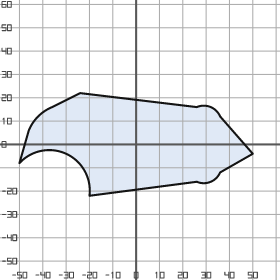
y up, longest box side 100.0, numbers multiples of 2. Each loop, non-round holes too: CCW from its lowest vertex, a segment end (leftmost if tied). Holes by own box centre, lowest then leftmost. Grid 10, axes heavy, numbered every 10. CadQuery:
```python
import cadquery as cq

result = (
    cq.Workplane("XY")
    .moveTo(-20.0, -22.0)
    .lineTo(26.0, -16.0)
    .threePointArc((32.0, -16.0), (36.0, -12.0))
    .lineTo(50.0, -4.0)
    .lineTo(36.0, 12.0)
    .threePointArc((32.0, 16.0), (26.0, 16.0))
    .lineTo(-24.0, 22.0)
    .lineTo(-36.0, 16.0)
    .threePointArc((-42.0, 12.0), (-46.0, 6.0))
    .lineTo(-50.0, -8.0)
    .threePointArc((-30.0, -4.0), (-20.0, -22.0))
    .close()
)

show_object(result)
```